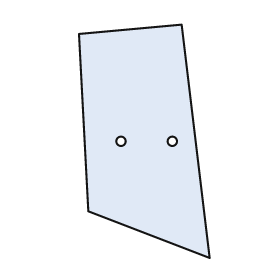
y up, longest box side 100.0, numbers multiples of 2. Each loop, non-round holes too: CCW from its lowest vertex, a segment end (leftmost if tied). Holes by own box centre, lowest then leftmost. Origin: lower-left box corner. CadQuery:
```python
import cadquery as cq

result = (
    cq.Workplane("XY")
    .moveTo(56.0, 0.0)
    .lineTo(44.0, 100.0)
    .lineTo(0.0, 96.0)
    .lineTo(4.0, 20.0)
    .close()
    .moveTo(18.0, 50.0)
    .circle(2.0)
    .moveTo(40.0, 50.0)
    .circle(2.0)
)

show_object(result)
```